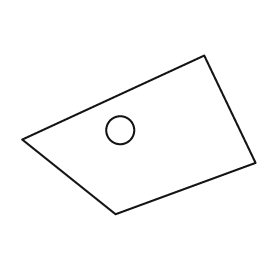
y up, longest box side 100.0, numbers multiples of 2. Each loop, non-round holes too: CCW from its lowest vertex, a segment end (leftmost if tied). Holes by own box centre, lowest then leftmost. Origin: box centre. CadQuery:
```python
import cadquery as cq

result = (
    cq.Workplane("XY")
    .moveTo(-10.0, -34.0)
    .lineTo(50.0, -12.0)
    .lineTo(28.0, 34.0)
    .lineTo(-50.0, -2.0)
    .close()
    .moveTo(-8.0, 2.0)
    .circle(6.0)
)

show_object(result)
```